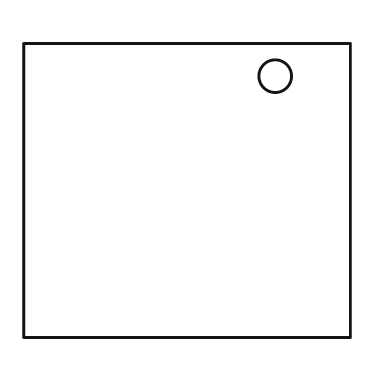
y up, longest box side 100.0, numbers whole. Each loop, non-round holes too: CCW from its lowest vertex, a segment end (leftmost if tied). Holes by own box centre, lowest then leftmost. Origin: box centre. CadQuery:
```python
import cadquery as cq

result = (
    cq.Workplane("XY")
    .moveTo(-50.0, -45.0)
    .lineTo(50.0, -45.0)
    .lineTo(50.0, 45.0)
    .lineTo(-50.0, 45.0)
    .close()
    .moveTo(27.0, 35.0)
    .circle(5.0)
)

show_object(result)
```